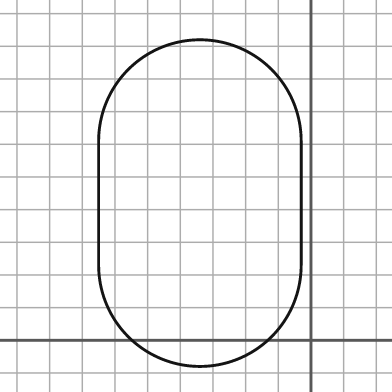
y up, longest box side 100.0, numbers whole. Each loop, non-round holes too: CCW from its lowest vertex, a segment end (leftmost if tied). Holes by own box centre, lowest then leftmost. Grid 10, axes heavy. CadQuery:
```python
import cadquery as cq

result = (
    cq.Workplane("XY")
    .moveTo(-65.0, 23.0)
    .threePointArc((-34.0, -8.0), (-3.0, 23.0))
    .lineTo(-3.0, 61.0)
    .threePointArc((-34.0, 92.0), (-65.0, 61.0))
    .close()
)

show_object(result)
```